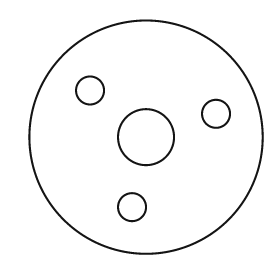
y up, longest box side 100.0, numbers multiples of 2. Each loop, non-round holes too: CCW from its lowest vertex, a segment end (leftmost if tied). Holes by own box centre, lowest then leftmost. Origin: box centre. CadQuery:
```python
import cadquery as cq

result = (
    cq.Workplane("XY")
    .moveTo(0.0, 0.0)
    .circle(50.0)
    .moveTo(-6.0, -30.0)
    .circle(6.0)
    .moveTo(0.0, 0.0)
    .circle(12.0)
    .moveTo(30.0, 10.0)
    .circle(6.0)
    .moveTo(-24.0, 20.0)
    .circle(6.0)
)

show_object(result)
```